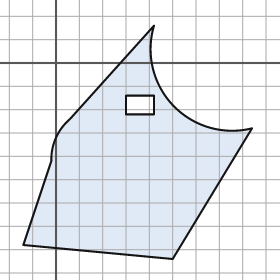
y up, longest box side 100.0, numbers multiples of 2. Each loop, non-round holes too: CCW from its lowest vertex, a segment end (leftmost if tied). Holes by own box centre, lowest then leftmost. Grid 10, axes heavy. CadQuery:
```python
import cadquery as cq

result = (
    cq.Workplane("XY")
    .moveTo(50.0, -84.0)
    .lineTo(84.0, -28.0)
    .threePointArc((50.0, -18.0), (42.0, 16.0))
    .lineTo(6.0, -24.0)
    .threePointArc((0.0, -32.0), (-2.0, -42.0))
    .lineTo(-14.0, -78.0)
    .close()
    .moveTo(30.0, -22.0)
    .lineTo(42.0, -22.0)
    .lineTo(42.0, -14.0)
    .lineTo(30.0, -14.0)
    .close()
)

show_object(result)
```